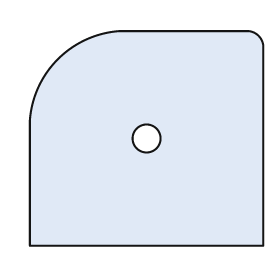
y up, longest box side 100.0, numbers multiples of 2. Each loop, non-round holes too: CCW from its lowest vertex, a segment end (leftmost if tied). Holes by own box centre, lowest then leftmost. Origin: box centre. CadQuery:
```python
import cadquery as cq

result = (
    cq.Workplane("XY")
    .moveTo(-50.0, -46.0)
    .lineTo(50.0, -46.0)
    .lineTo(50.0, 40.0)
    .threePointArc((48.0, 44.0), (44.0, 46.0))
    .lineTo(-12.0, 46.0)
    .threePointArc((-38.0, 34.0), (-50.0, 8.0))
    .close()
    .moveTo(0.0, 0.0)
    .circle(6.0)
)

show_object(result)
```